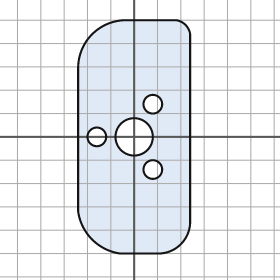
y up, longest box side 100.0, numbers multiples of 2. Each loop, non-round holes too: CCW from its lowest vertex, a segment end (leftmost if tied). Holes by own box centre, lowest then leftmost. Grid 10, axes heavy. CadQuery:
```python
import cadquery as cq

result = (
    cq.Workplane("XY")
    .moveTo(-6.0, -50.0)
    .lineTo(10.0, -50.0)
    .threePointArc((20.0, -46.0), (24.0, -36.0))
    .lineTo(24.0, 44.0)
    .threePointArc((22.0, 48.0), (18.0, 50.0))
    .lineTo(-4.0, 50.0)
    .threePointArc((-18.0, 44.0), (-24.0, 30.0))
    .lineTo(-24.0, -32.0)
    .threePointArc((-18.0, -44.0), (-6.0, -50.0))
    .close()
    .moveTo(8.0, -14.0)
    .circle(4.0)
    .moveTo(-16.0, 0.0)
    .circle(4.0)
    .moveTo(0.0, 0.0)
    .circle(8.0)
    .moveTo(8.0, 14.0)
    .circle(4.0)
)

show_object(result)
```